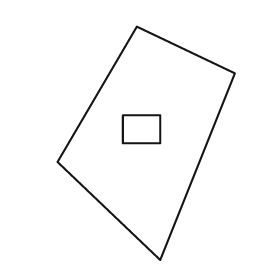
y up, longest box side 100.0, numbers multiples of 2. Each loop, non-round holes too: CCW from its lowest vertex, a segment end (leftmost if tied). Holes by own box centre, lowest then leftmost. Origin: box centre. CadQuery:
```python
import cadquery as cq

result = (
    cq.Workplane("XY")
    .moveTo(6.0, -50.0)
    .lineTo(38.0, 30.0)
    .lineTo(-4.0, 50.0)
    .lineTo(-38.0, -8.0)
    .close()
    .moveTo(-10.0, 0.0)
    .lineTo(6.0, 0.0)
    .lineTo(6.0, 12.0)
    .lineTo(-10.0, 12.0)
    .close()
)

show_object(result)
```